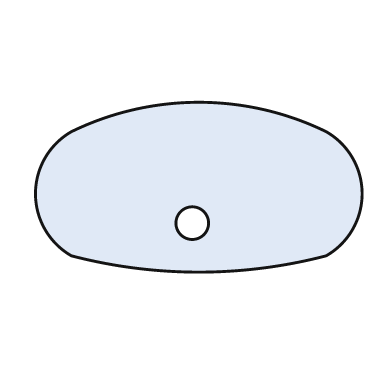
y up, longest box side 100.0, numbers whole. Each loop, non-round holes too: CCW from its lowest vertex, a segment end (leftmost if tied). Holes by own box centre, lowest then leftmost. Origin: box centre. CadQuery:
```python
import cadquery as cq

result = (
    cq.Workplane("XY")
    .moveTo(-39.0, -21.0)
    .threePointArc((0.0, -26.0), (39.0, -21.0))
    .threePointArc((50.0, -2.0), (39.0, 17.0))
    .threePointArc((0.0, 26.0), (-39.0, 17.0))
    .threePointArc((-50.0, -2.0), (-39.0, -21.0))
    .close()
    .moveTo(-2.0, -11.0)
    .circle(5.0)
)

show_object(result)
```